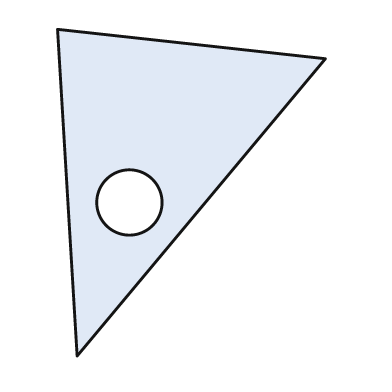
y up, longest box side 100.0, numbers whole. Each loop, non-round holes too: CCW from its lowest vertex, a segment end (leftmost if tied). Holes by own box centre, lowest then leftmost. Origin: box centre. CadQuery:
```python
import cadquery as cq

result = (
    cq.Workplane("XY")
    .moveTo(-35.0, -50.0)
    .lineTo(41.0, 41.0)
    .lineTo(-41.0, 50.0)
    .close()
    .moveTo(-19.0, -3.0)
    .circle(10.0)
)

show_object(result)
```